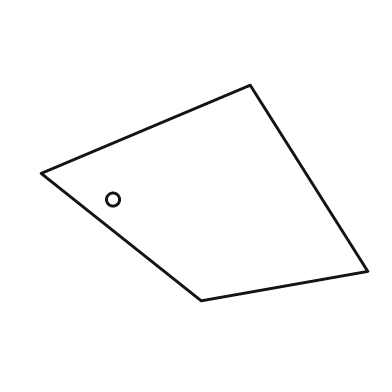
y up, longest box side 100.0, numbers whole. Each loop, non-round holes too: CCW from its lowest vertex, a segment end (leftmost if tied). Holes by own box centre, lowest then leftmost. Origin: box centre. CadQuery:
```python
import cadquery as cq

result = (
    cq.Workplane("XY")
    .moveTo(-1.0, -33.0)
    .lineTo(50.0, -24.0)
    .lineTo(14.0, 33.0)
    .lineTo(-50.0, 6.0)
    .close()
    .moveTo(-28.0, -2.0)
    .circle(2.0)
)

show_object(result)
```